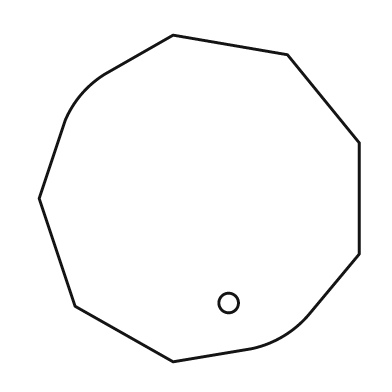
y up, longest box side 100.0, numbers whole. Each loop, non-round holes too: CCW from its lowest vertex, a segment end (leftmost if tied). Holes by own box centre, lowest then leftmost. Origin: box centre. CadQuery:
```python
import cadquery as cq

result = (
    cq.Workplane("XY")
    .moveTo(-8.0, -50.0)
    .lineTo(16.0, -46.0)
    .threePointArc((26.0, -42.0), (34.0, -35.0))
    .lineTo(49.0, -17.0)
    .lineTo(49.0, 17.0)
    .lineTo(27.0, 44.0)
    .lineTo(-8.0, 50.0)
    .lineTo(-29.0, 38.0)
    .threePointArc((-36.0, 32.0), (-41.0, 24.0))
    .lineTo(-49.0, 0.0)
    .lineTo(-38.0, -33.0)
    .close()
    .moveTo(9.0, -32.0)
    .circle(3.0)
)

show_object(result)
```